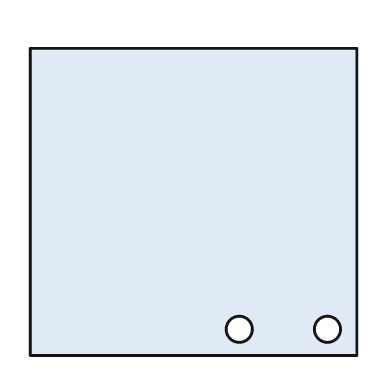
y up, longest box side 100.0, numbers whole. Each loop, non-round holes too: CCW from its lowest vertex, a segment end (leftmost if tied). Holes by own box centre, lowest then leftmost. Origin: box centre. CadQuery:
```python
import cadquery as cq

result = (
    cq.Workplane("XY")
    .moveTo(-50.0, -47.0)
    .lineTo(50.0, -47.0)
    .lineTo(50.0, 47.0)
    .lineTo(-50.0, 47.0)
    .close()
    .moveTo(14.0, -39.0)
    .circle(4.0)
    .moveTo(41.0, -39.0)
    .circle(4.0)
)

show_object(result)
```